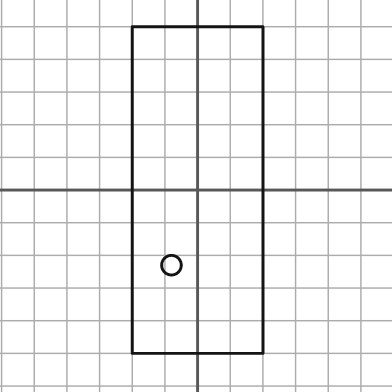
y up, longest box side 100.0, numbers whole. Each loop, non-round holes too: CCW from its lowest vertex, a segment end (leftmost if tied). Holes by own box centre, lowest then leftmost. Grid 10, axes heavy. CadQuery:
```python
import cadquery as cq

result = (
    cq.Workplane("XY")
    .moveTo(-20.0, -50.0)
    .lineTo(20.0, -50.0)
    .lineTo(20.0, 50.0)
    .lineTo(-20.0, 50.0)
    .close()
    .moveTo(-8.0, -23.0)
    .circle(3.0)
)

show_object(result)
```